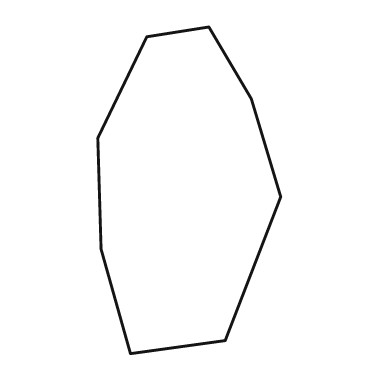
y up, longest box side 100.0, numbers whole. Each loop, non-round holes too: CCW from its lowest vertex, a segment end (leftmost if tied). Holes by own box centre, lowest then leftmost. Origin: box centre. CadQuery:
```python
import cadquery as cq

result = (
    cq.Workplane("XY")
    .moveTo(-18.0, -50.0)
    .lineTo(11.0, -46.0)
    .lineTo(28.0, -2.0)
    .lineTo(19.0, 28.0)
    .lineTo(6.0, 50.0)
    .lineTo(-13.0, 47.0)
    .lineTo(-28.0, 16.0)
    .lineTo(-27.0, -18.0)
    .close()
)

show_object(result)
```